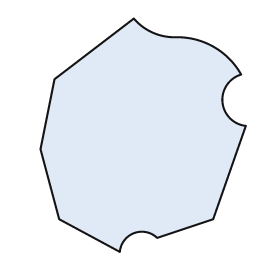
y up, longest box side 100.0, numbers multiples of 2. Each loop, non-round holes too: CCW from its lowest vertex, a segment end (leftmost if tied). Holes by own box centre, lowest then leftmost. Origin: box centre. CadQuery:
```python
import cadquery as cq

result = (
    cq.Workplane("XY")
    .moveTo(-10.0, -50.0)
    .threePointArc((-4.0, -42.0), (6.0, -44.0))
    .lineTo(30.0, -36.0)
    .lineTo(44.0, 4.0)
    .threePointArc((34.0, 14.0), (42.0, 26.0))
    .threePointArc((30.0, 38.0), (14.0, 42.0))
    .threePointArc((4.0, 44.0), (-4.0, 50.0))
    .lineTo(-38.0, 24.0)
    .lineTo(-44.0, -6.0)
    .lineTo(-36.0, -36.0)
    .close()
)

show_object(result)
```